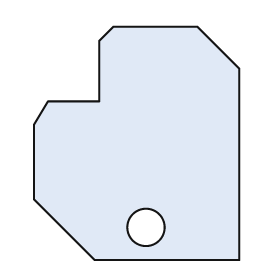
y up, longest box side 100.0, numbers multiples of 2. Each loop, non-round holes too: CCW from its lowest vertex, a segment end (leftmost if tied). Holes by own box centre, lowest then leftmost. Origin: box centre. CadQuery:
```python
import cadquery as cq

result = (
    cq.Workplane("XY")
    .moveTo(-18.0, -50.0)
    .lineTo(44.0, -50.0)
    .lineTo(44.0, 32.0)
    .lineTo(26.0, 50.0)
    .lineTo(-10.0, 50.0)
    .lineTo(-16.0, 44.0)
    .lineTo(-16.0, 18.0)
    .lineTo(-38.0, 18.0)
    .lineTo(-44.0, 8.0)
    .lineTo(-44.0, -24.0)
    .close()
    .moveTo(4.0, -36.0)
    .circle(8.0)
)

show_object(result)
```